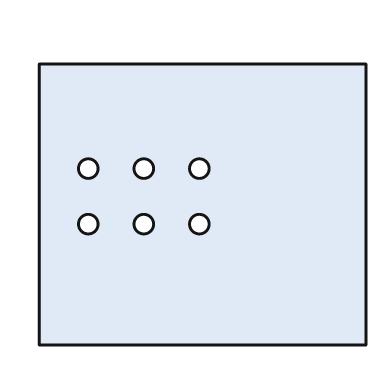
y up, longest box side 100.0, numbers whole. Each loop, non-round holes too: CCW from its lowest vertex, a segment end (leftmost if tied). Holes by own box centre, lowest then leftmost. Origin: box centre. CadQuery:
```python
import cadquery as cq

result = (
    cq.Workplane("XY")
    .moveTo(-50.0, -43.0)
    .lineTo(50.0, -43.0)
    .lineTo(50.0, 43.0)
    .lineTo(-50.0, 43.0)
    .close()
    .moveTo(-35.0, -6.0)
    .circle(3.0)
    .moveTo(-18.0, -6.0)
    .circle(3.0)
    .moveTo(-1.0, -6.0)
    .circle(3.0)
    .moveTo(-35.0, 11.0)
    .circle(3.0)
    .moveTo(-18.0, 11.0)
    .circle(3.0)
    .moveTo(-1.0, 11.0)
    .circle(3.0)
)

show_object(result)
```